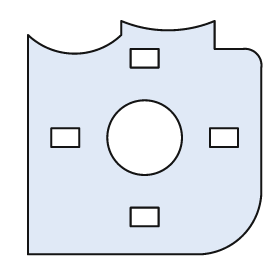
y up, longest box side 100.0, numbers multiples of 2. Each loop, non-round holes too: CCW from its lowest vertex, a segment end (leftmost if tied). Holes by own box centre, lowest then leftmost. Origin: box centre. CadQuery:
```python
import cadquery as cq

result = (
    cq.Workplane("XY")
    .moveTo(-50.0, -50.0)
    .lineTo(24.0, -50.0)
    .threePointArc((42.0, -42.0), (50.0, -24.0))
    .lineTo(50.0, 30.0)
    .threePointArc((48.0, 36.0), (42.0, 38.0))
    .lineTo(30.0, 38.0)
    .lineTo(30.0, 50.0)
    .threePointArc((10.0, 46.0), (-10.0, 50.0))
    .lineTo(-10.0, 44.0)
    .threePointArc((-30.0, 36.0), (-50.0, 44.0))
    .close()
    .moveTo(-6.0, -38.0)
    .lineTo(6.0, -38.0)
    .lineTo(6.0, -30.0)
    .lineTo(-6.0, -30.0)
    .close()
    .moveTo(-40.0, -4.0)
    .lineTo(-28.0, -4.0)
    .lineTo(-28.0, 4.0)
    .lineTo(-40.0, 4.0)
    .close()
    .moveTo(0.0, 0.0)
    .circle(16.0)
    .moveTo(28.0, -4.0)
    .lineTo(40.0, -4.0)
    .lineTo(40.0, 4.0)
    .lineTo(28.0, 4.0)
    .close()
    .moveTo(-6.0, 30.0)
    .lineTo(6.0, 30.0)
    .lineTo(6.0, 38.0)
    .lineTo(-6.0, 38.0)
    .close()
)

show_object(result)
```